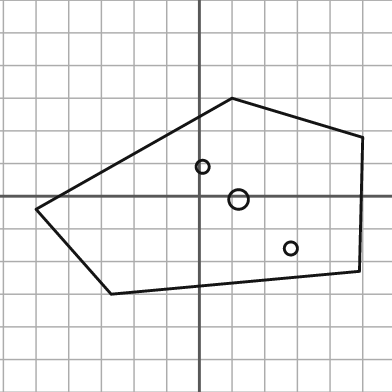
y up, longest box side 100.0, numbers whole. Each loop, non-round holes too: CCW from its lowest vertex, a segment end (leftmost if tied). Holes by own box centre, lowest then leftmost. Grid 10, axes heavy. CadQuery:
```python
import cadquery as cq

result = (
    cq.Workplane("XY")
    .moveTo(-27.0, -30.0)
    .lineTo(49.0, -23.0)
    .lineTo(50.0, 18.0)
    .lineTo(10.0, 30.0)
    .lineTo(-50.0, -4.0)
    .close()
    .moveTo(28.0, -16.0)
    .circle(2.0)
    .moveTo(12.0, -1.0)
    .circle(3.0)
    .moveTo(1.0, 9.0)
    .circle(2.0)
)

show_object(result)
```